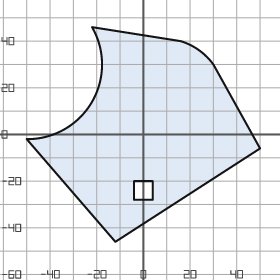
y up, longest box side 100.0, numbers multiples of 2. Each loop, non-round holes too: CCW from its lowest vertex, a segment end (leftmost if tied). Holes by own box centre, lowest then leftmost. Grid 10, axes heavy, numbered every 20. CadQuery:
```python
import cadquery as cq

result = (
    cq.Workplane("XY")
    .moveTo(-12.0, -46.0)
    .lineTo(50.0, -6.0)
    .lineTo(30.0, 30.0)
    .threePointArc((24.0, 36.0), (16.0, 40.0))
    .lineTo(-22.0, 46.0)
    .threePointArc((-22.0, 14.0), (-50.0, -2.0))
    .close()
    .moveTo(-4.0, -28.0)
    .lineTo(4.0, -28.0)
    .lineTo(4.0, -20.0)
    .lineTo(-4.0, -20.0)
    .close()
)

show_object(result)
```